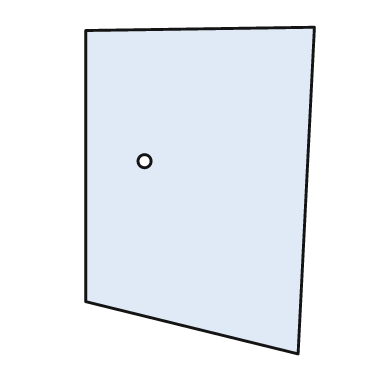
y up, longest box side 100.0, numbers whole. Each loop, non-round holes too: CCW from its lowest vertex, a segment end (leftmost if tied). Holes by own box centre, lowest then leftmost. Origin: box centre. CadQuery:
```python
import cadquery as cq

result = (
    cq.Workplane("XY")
    .moveTo(30.0, -50.0)
    .lineTo(35.0, 50.0)
    .lineTo(-35.0, 49.0)
    .lineTo(-35.0, -34.0)
    .close()
    .moveTo(-17.0, 9.0)
    .circle(2.0)
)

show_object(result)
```